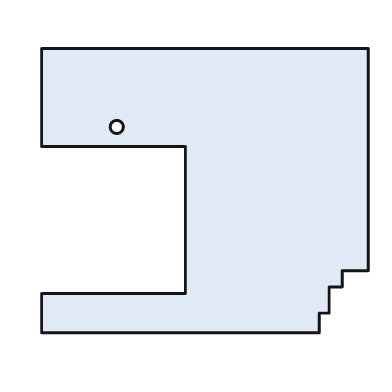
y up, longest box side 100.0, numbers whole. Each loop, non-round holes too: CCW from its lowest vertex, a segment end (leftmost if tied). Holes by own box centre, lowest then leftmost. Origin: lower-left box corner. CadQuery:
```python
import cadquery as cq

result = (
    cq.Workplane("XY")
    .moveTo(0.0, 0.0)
    .lineTo(85.0, 0.0)
    .lineTo(85.0, 6.0)
    .lineTo(88.0, 6.0)
    .lineTo(88.0, 14.0)
    .lineTo(92.0, 14.0)
    .lineTo(92.0, 19.0)
    .lineTo(100.0, 19.0)
    .lineTo(100.0, 87.0)
    .lineTo(0.0, 87.0)
    .lineTo(0.0, 57.0)
    .lineTo(44.0, 57.0)
    .lineTo(44.0, 12.0)
    .lineTo(0.0, 12.0)
    .close()
    .moveTo(23.0, 63.0)
    .circle(2.0)
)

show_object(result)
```